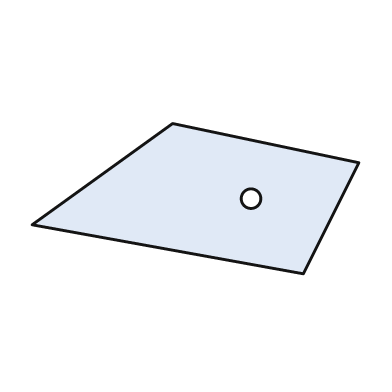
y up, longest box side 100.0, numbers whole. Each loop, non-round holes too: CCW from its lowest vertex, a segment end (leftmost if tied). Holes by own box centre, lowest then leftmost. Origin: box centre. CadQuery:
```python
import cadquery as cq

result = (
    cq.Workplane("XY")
    .moveTo(33.0, -23.0)
    .lineTo(50.0, 11.0)
    .lineTo(-7.0, 23.0)
    .lineTo(-50.0, -8.0)
    .close()
    .moveTo(17.0, 0.0)
    .circle(3.0)
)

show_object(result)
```